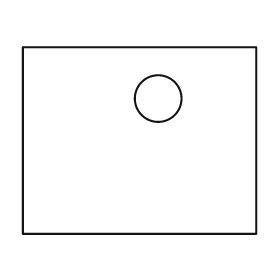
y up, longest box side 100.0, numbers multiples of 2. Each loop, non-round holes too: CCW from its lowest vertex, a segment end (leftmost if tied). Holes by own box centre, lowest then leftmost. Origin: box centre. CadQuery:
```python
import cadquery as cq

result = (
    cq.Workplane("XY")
    .moveTo(-50.0, -40.0)
    .lineTo(50.0, -40.0)
    .lineTo(50.0, 40.0)
    .lineTo(-50.0, 40.0)
    .close()
    .moveTo(8.0, 18.0)
    .circle(10.0)
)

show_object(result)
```